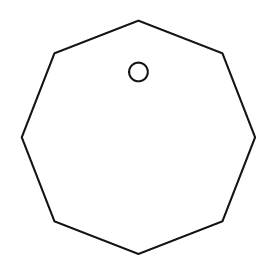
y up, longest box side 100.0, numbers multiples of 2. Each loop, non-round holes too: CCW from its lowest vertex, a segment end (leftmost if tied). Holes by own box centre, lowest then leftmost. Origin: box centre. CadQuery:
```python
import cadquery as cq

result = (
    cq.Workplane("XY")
    .moveTo(0.0, -50.0)
    .lineTo(36.0, -36.0)
    .lineTo(50.0, 0.0)
    .lineTo(36.0, 36.0)
    .lineTo(0.0, 50.0)
    .lineTo(-36.0, 36.0)
    .lineTo(-50.0, 0.0)
    .lineTo(-36.0, -36.0)
    .close()
    .moveTo(0.0, 28.0)
    .circle(4.0)
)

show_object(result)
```